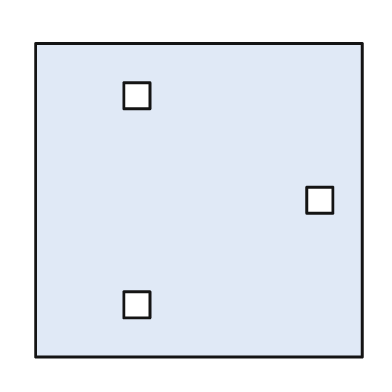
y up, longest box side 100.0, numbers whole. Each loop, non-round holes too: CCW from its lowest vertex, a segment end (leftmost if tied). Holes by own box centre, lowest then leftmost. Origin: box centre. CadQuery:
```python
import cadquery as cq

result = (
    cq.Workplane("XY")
    .moveTo(-50.0, -48.0)
    .lineTo(50.0, -48.0)
    .lineTo(50.0, 48.0)
    .lineTo(-50.0, 48.0)
    .close()
    .moveTo(-23.0, -36.0)
    .lineTo(-15.0, -36.0)
    .lineTo(-15.0, -28.0)
    .lineTo(-23.0, -28.0)
    .close()
    .moveTo(33.0, -4.0)
    .lineTo(41.0, -4.0)
    .lineTo(41.0, 4.0)
    .lineTo(33.0, 4.0)
    .close()
    .moveTo(-23.0, 28.0)
    .lineTo(-15.0, 28.0)
    .lineTo(-15.0, 36.0)
    .lineTo(-23.0, 36.0)
    .close()
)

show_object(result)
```